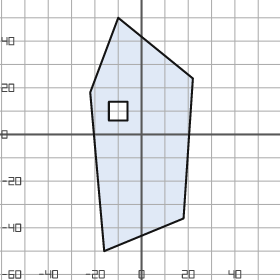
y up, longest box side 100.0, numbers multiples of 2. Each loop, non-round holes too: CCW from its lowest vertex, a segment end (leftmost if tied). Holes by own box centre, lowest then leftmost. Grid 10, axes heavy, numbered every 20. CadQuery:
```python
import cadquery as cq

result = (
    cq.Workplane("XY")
    .moveTo(-16.0, -50.0)
    .lineTo(18.0, -36.0)
    .lineTo(22.0, 24.0)
    .lineTo(-10.0, 50.0)
    .lineTo(-22.0, 18.0)
    .close()
    .moveTo(-14.0, 6.0)
    .lineTo(-6.0, 6.0)
    .lineTo(-6.0, 14.0)
    .lineTo(-14.0, 14.0)
    .close()
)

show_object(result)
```